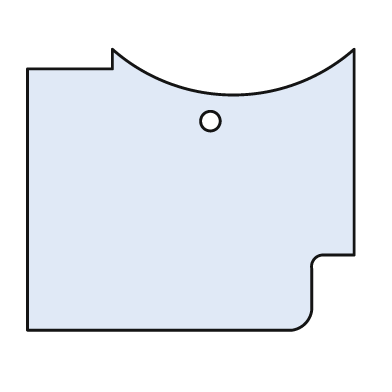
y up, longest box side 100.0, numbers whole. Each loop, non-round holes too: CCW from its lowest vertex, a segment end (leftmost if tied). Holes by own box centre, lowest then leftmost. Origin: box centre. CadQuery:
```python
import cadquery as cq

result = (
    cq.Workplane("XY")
    .moveTo(-50.0, -43.0)
    .lineTo(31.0, -43.0)
    .threePointArc((35.0, -41.0), (37.0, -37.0))
    .lineTo(37.0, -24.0)
    .threePointArc((38.0, -21.0), (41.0, -20.0))
    .lineTo(50.0, -20.0)
    .lineTo(50.0, 43.0)
    .threePointArc((13.0, 29.0), (-24.0, 43.0))
    .lineTo(-24.0, 37.0)
    .lineTo(-50.0, 37.0)
    .close()
    .moveTo(6.0, 21.0)
    .circle(3.0)
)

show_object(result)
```